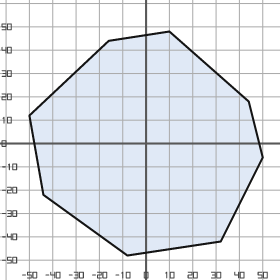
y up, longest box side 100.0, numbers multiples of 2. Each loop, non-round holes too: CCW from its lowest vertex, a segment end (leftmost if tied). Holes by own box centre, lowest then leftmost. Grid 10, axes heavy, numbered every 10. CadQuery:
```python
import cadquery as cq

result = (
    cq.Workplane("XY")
    .moveTo(-8.0, -48.0)
    .lineTo(32.0, -42.0)
    .lineTo(50.0, -6.0)
    .lineTo(44.0, 18.0)
    .lineTo(10.0, 48.0)
    .lineTo(-16.0, 44.0)
    .lineTo(-50.0, 12.0)
    .lineTo(-44.0, -22.0)
    .close()
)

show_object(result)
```